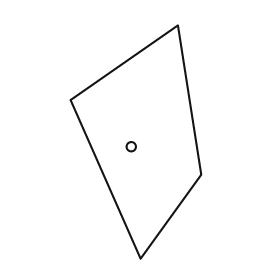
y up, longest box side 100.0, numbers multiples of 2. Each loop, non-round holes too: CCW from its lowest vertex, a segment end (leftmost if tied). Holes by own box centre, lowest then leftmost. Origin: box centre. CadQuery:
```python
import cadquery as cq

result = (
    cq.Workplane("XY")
    .moveTo(2.0, -50.0)
    .lineTo(28.0, -14.0)
    .lineTo(18.0, 50.0)
    .lineTo(-28.0, 18.0)
    .close()
    .moveTo(-2.0, -2.0)
    .circle(2.0)
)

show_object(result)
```